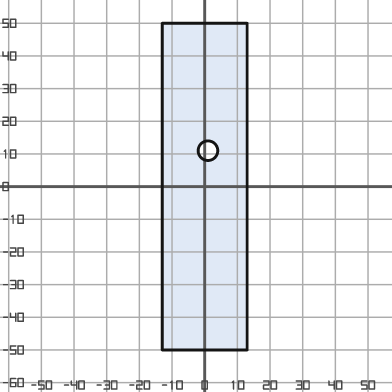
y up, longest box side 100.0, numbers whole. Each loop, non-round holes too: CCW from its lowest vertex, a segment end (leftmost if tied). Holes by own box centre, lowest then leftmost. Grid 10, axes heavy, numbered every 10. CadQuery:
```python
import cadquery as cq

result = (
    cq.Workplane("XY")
    .moveTo(-13.0, -50.0)
    .lineTo(13.0, -50.0)
    .lineTo(13.0, 50.0)
    .lineTo(-13.0, 50.0)
    .close()
    .moveTo(1.0, 11.0)
    .circle(3.0)
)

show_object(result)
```